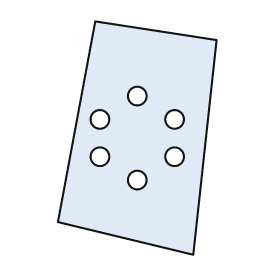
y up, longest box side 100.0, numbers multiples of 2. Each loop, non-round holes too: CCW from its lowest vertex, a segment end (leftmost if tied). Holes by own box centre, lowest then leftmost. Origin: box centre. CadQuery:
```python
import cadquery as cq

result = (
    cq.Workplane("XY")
    .moveTo(24.0, -50.0)
    .lineTo(34.0, 42.0)
    .lineTo(-18.0, 50.0)
    .lineTo(-34.0, -36.0)
    .close()
    .moveTo(0.0, -18.0)
    .circle(4.0)
    .moveTo(-16.0, -8.0)
    .circle(4.0)
    .moveTo(16.0, -8.0)
    .circle(4.0)
    .moveTo(-16.0, 8.0)
    .circle(4.0)
    .moveTo(16.0, 8.0)
    .circle(4.0)
    .moveTo(0.0, 18.0)
    .circle(4.0)
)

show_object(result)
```